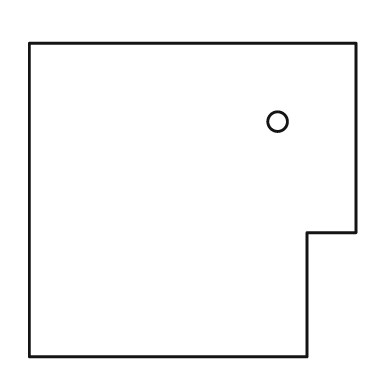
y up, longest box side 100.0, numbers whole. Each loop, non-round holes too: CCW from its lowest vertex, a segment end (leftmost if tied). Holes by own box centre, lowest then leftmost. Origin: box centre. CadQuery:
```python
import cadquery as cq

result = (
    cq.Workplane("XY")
    .moveTo(-50.0, -48.0)
    .lineTo(35.0, -48.0)
    .lineTo(35.0, -10.0)
    .lineTo(50.0, -10.0)
    .lineTo(50.0, 48.0)
    .lineTo(-50.0, 48.0)
    .close()
    .moveTo(26.0, 24.0)
    .circle(3.0)
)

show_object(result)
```